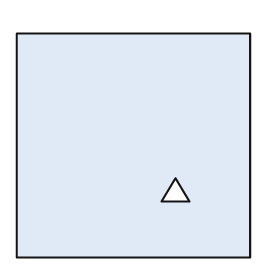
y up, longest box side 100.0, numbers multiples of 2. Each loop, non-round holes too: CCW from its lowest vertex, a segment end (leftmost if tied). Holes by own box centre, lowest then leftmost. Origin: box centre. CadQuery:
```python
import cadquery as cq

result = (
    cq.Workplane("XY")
    .moveTo(-50.0, -48.0)
    .lineTo(50.0, -48.0)
    .lineTo(50.0, 48.0)
    .lineTo(-50.0, 48.0)
    .close()
    .moveTo(12.0, -24.0)
    .lineTo(24.0, -24.0)
    .lineTo(18.0, -14.0)
    .close()
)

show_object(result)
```